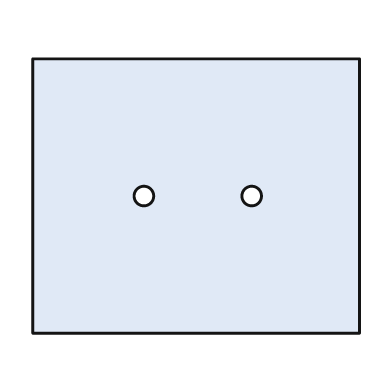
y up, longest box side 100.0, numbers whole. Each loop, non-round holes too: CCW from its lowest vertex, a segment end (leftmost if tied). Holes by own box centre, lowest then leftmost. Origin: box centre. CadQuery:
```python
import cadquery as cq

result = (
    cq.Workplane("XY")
    .moveTo(-50.0, -42.0)
    .lineTo(50.0, -42.0)
    .lineTo(50.0, 42.0)
    .lineTo(-50.0, 42.0)
    .close()
    .moveTo(-16.0, 0.0)
    .circle(3.0)
    .moveTo(17.0, 0.0)
    .circle(3.0)
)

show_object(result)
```